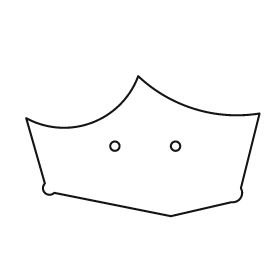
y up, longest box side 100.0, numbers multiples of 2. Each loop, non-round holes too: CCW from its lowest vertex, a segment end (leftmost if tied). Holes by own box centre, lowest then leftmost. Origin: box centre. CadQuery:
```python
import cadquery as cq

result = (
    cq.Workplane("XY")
    .moveTo(12.0, -30.0)
    .lineTo(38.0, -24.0)
    .threePointArc((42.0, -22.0), (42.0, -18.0))
    .lineTo(50.0, 14.0)
    .threePointArc((22.0, 16.0), (-2.0, 30.0))
    .threePointArc((-22.0, 10.0), (-50.0, 12.0))
    .lineTo(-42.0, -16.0)
    .threePointArc((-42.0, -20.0), (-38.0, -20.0))
    .close()
    .moveTo(-12.0, 0.0)
    .circle(2.0)
    .moveTo(14.0, 0.0)
    .circle(2.0)
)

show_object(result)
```